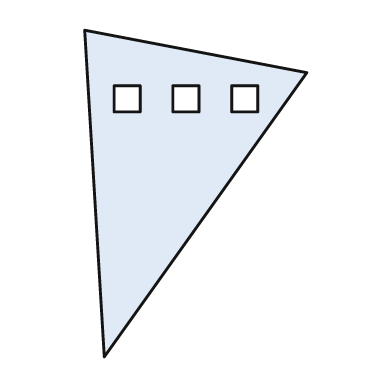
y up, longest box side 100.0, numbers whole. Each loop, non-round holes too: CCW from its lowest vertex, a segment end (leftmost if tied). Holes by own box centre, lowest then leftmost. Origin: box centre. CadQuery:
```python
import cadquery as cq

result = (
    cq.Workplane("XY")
    .moveTo(-28.0, -50.0)
    .lineTo(34.0, 37.0)
    .lineTo(-34.0, 50.0)
    .close()
    .moveTo(-25.0, 25.0)
    .lineTo(-17.0, 25.0)
    .lineTo(-17.0, 33.0)
    .lineTo(-25.0, 33.0)
    .close()
    .moveTo(-7.0, 25.0)
    .lineTo(1.0, 25.0)
    .lineTo(1.0, 33.0)
    .lineTo(-7.0, 33.0)
    .close()
    .moveTo(11.0, 25.0)
    .lineTo(19.0, 25.0)
    .lineTo(19.0, 33.0)
    .lineTo(11.0, 33.0)
    .close()
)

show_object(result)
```